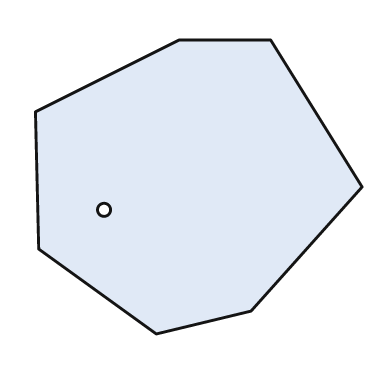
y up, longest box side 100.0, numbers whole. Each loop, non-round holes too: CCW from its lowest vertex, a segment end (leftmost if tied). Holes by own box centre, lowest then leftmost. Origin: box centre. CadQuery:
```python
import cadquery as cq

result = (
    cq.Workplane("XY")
    .moveTo(-13.0, -45.0)
    .lineTo(16.0, -38.0)
    .lineTo(50.0, 0.0)
    .lineTo(22.0, 45.0)
    .lineTo(-6.0, 45.0)
    .lineTo(-50.0, 23.0)
    .lineTo(-49.0, -19.0)
    .close()
    .moveTo(-29.0, -7.0)
    .circle(2.0)
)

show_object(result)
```